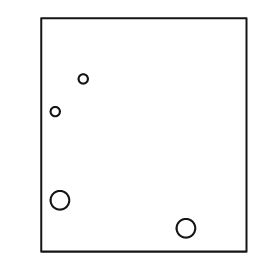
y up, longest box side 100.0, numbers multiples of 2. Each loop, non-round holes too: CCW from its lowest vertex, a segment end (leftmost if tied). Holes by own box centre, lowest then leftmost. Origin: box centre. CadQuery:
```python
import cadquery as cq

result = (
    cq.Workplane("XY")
    .moveTo(-44.0, -50.0)
    .lineTo(44.0, -50.0)
    .lineTo(44.0, 50.0)
    .lineTo(-44.0, 50.0)
    .close()
    .moveTo(18.0, -40.0)
    .circle(4.0)
    .moveTo(-36.0, -28.0)
    .circle(4.0)
    .moveTo(-38.0, 10.0)
    .circle(2.0)
    .moveTo(-26.0, 24.0)
    .circle(2.0)
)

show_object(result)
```